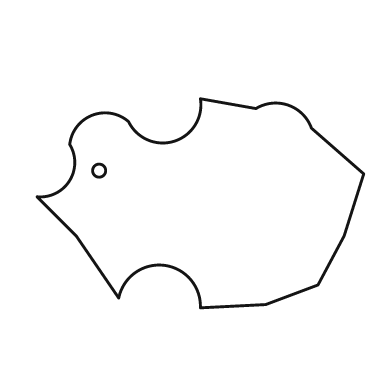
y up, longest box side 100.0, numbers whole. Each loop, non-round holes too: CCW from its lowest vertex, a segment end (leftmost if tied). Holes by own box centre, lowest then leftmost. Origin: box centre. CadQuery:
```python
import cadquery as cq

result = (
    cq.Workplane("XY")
    .moveTo(0.0, -32.0)
    .lineTo(20.0, -31.0)
    .lineTo(36.0, -25.0)
    .lineTo(44.0, -10.0)
    .lineTo(50.0, 9.0)
    .lineTo(34.0, 23.0)
    .threePointArc((27.0, 30.0), (17.0, 29.0))
    .lineTo(0.0, 32.0)
    .threePointArc((-8.0, 19.0), (-22.0, 25.0))
    .threePointArc((-33.0, 27.0), (-40.0, 18.0))
    .threePointArc((-40.0, 7.0), (-50.0, 2.0))
    .lineTo(-38.0, -10.0)
    .lineTo(-25.0, -29.0)
    .threePointArc((-11.0, -19.0), (0.0, -32.0))
    .close()
    .moveTo(-31.0, 10.0)
    .circle(2.0)
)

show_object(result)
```